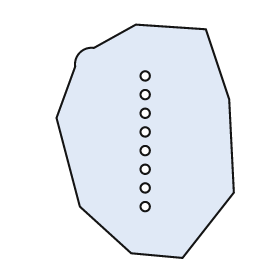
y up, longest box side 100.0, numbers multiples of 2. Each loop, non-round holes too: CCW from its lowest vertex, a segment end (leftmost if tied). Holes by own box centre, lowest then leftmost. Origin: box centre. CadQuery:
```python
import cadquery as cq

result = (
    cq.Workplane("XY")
    .moveTo(16.0, -50.0)
    .lineTo(38.0, -22.0)
    .lineTo(36.0, 18.0)
    .lineTo(26.0, 48.0)
    .lineTo(-4.0, 50.0)
    .lineTo(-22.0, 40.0)
    .threePointArc((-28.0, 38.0), (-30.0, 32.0))
    .lineTo(-38.0, 10.0)
    .lineTo(-28.0, -28.0)
    .lineTo(-6.0, -48.0)
    .close()
    .moveTo(0.0, -28.0)
    .circle(2.0)
    .moveTo(0.0, -20.0)
    .circle(2.0)
    .moveTo(0.0, -12.0)
    .circle(2.0)
    .moveTo(0.0, -4.0)
    .circle(2.0)
    .moveTo(0.0, 4.0)
    .circle(2.0)
    .moveTo(0.0, 12.0)
    .circle(2.0)
    .moveTo(0.0, 20.0)
    .circle(2.0)
    .moveTo(0.0, 28.0)
    .circle(2.0)
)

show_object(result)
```